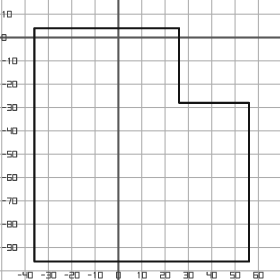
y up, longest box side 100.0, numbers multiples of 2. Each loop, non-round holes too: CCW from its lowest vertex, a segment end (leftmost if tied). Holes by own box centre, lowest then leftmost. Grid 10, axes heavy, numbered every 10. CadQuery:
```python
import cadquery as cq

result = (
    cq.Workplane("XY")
    .moveTo(-36.0, -96.0)
    .lineTo(56.0, -96.0)
    .lineTo(56.0, -28.0)
    .lineTo(26.0, -28.0)
    .lineTo(26.0, 4.0)
    .lineTo(-36.0, 4.0)
    .close()
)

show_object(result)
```